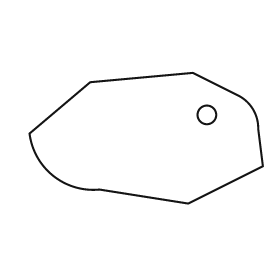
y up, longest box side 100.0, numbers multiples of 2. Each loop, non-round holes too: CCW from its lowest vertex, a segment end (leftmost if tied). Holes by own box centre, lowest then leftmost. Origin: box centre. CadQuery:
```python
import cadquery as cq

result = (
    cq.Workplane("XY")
    .moveTo(18.0, -28.0)
    .lineTo(50.0, -12.0)
    .lineTo(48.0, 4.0)
    .threePointArc((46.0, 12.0), (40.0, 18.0))
    .lineTo(20.0, 28.0)
    .lineTo(-24.0, 24.0)
    .lineTo(-50.0, 2.0)
    .threePointArc((-40.0, -16.0), (-20.0, -22.0))
    .close()
    .moveTo(26.0, 10.0)
    .circle(4.0)
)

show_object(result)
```